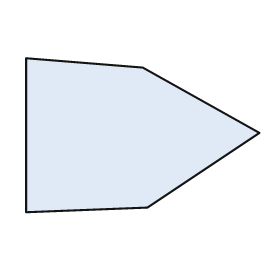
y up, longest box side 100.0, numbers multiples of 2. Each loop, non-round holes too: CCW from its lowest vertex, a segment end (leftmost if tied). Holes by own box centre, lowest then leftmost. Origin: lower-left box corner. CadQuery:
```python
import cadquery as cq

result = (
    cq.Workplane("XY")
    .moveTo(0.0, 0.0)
    .lineTo(52.0, 2.0)
    .lineTo(100.0, 34.0)
    .lineTo(50.0, 62.0)
    .lineTo(0.0, 66.0)
    .close()
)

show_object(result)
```